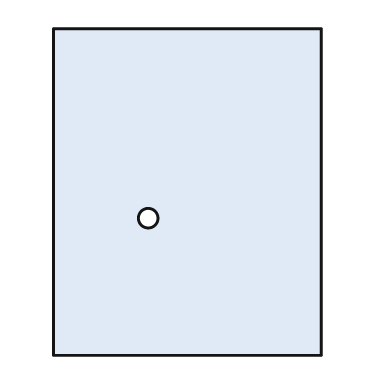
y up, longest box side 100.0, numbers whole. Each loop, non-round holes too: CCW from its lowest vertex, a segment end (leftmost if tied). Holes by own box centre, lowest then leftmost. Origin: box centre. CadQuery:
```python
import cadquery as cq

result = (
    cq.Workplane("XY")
    .moveTo(-41.0, -50.0)
    .lineTo(41.0, -50.0)
    .lineTo(41.0, 50.0)
    .lineTo(-41.0, 50.0)
    .close()
    .moveTo(-12.0, -8.0)
    .circle(3.0)
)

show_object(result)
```